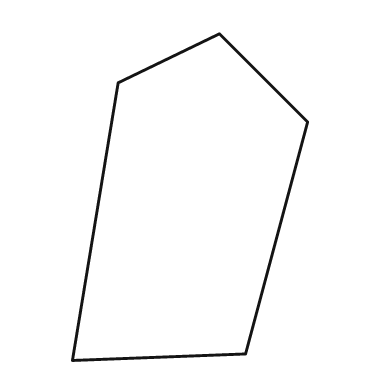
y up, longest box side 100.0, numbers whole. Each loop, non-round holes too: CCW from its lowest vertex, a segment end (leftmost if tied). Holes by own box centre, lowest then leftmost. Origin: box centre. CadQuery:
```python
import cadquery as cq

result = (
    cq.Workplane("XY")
    .moveTo(-36.0, -50.0)
    .lineTo(17.0, -48.0)
    .lineTo(36.0, 23.0)
    .lineTo(9.0, 50.0)
    .lineTo(-22.0, 35.0)
    .close()
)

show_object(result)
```